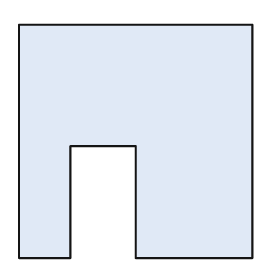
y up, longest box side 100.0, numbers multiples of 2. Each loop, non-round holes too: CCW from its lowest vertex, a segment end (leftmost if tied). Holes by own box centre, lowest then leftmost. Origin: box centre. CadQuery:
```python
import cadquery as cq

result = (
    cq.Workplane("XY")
    .moveTo(-50.0, -50.0)
    .lineTo(-28.0, -50.0)
    .lineTo(-28.0, -2.0)
    .lineTo(0.0, -2.0)
    .lineTo(0.0, -50.0)
    .lineTo(50.0, -50.0)
    .lineTo(50.0, 50.0)
    .lineTo(-50.0, 50.0)
    .close()
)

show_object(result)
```